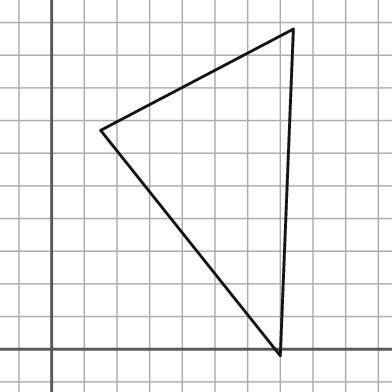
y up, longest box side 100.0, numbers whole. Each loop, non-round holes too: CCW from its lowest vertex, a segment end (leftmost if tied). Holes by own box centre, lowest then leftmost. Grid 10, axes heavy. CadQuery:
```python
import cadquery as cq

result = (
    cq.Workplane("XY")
    .moveTo(70.0, -2.0)
    .lineTo(74.0, 98.0)
    .lineTo(15.0, 67.0)
    .close()
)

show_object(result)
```